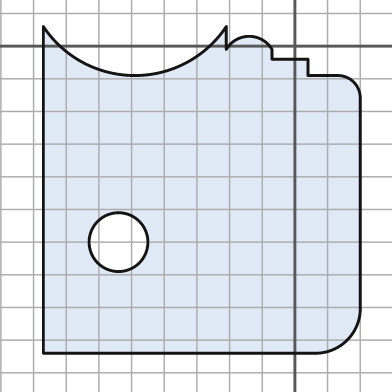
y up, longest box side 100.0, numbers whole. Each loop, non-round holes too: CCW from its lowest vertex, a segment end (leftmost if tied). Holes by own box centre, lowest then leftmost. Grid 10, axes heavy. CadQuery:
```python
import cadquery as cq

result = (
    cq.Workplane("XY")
    .moveTo(-77.0, -94.0)
    .lineTo(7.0, -94.0)
    .threePointArc((16.0, -90.0), (20.0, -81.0))
    .lineTo(20.0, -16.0)
    .threePointArc((18.0, -11.0), (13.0, -9.0))
    .lineTo(4.0, -9.0)
    .lineTo(4.0, -4.0)
    .lineTo(-7.0, -4.0)
    .lineTo(-7.0, -1.0)
    .threePointArc((-14.0, 3.0), (-21.0, -1.0))
    .lineTo(-21.0, 6.0)
    .threePointArc((-49.0, -9.0), (-77.0, 6.0))
    .close()
    .moveTo(-54.0, -60.0)
    .circle(9.0)
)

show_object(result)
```